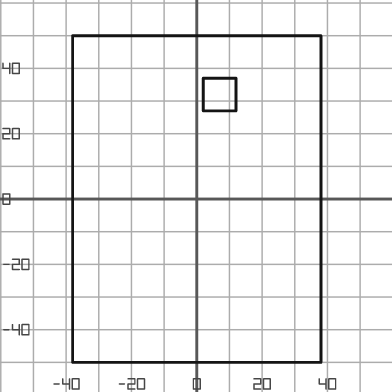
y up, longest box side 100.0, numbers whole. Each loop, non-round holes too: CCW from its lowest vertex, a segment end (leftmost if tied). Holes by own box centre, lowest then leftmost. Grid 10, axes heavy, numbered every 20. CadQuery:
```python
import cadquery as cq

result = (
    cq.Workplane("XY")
    .moveTo(-38.0, -50.0)
    .lineTo(38.0, -50.0)
    .lineTo(38.0, 50.0)
    .lineTo(-38.0, 50.0)
    .close()
    .moveTo(2.0, 27.0)
    .lineTo(12.0, 27.0)
    .lineTo(12.0, 37.0)
    .lineTo(2.0, 37.0)
    .close()
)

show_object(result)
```